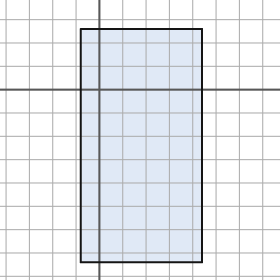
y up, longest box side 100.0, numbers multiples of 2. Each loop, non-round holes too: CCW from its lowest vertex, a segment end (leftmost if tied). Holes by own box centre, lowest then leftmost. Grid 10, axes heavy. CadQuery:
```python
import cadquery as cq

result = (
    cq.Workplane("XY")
    .moveTo(-8.0, -74.0)
    .lineTo(44.0, -74.0)
    .lineTo(44.0, 26.0)
    .lineTo(-8.0, 26.0)
    .close()
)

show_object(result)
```